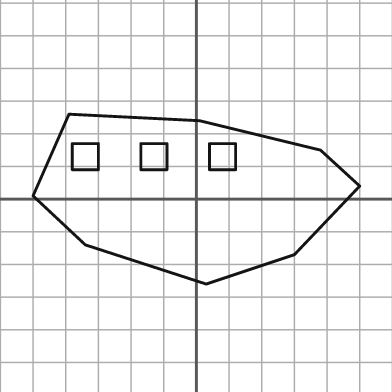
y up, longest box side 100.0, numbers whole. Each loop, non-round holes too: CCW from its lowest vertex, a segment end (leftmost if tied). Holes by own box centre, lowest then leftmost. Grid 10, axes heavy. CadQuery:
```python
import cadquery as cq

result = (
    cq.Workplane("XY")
    .moveTo(3.0, -26.0)
    .lineTo(30.0, -17.0)
    .lineTo(50.0, 4.0)
    .lineTo(38.0, 15.0)
    .lineTo(1.0, 24.0)
    .lineTo(-39.0, 26.0)
    .lineTo(-50.0, 1.0)
    .lineTo(-34.0, -14.0)
    .close()
    .moveTo(-38.0, 9.0)
    .lineTo(-30.0, 9.0)
    .lineTo(-30.0, 17.0)
    .lineTo(-38.0, 17.0)
    .close()
    .moveTo(-17.0, 9.0)
    .lineTo(-9.0, 9.0)
    .lineTo(-9.0, 17.0)
    .lineTo(-17.0, 17.0)
    .close()
    .moveTo(4.0, 9.0)
    .lineTo(12.0, 9.0)
    .lineTo(12.0, 17.0)
    .lineTo(4.0, 17.0)
    .close()
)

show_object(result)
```